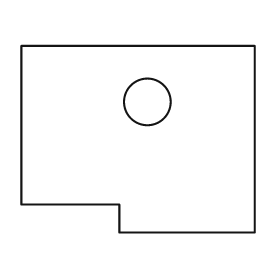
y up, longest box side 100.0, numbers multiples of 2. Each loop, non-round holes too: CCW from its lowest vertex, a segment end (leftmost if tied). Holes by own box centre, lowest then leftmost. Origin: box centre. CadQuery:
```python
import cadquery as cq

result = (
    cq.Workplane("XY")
    .moveTo(-8.0, -40.0)
    .lineTo(50.0, -40.0)
    .lineTo(50.0, 40.0)
    .lineTo(-50.0, 40.0)
    .lineTo(-50.0, -28.0)
    .lineTo(-8.0, -28.0)
    .close()
    .moveTo(4.0, 16.0)
    .circle(10.0)
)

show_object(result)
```